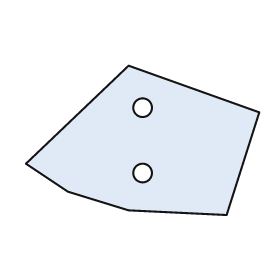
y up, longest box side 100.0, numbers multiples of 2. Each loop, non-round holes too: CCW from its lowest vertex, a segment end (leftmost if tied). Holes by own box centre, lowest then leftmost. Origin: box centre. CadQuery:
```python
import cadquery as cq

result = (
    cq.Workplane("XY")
    .moveTo(36.0, -32.0)
    .lineTo(50.0, 12.0)
    .lineTo(-6.0, 32.0)
    .lineTo(-50.0, -10.0)
    .lineTo(-32.0, -22.0)
    .lineTo(-6.0, -30.0)
    .close()
    .moveTo(0.0, -14.0)
    .circle(4.0)
    .moveTo(0.0, 14.0)
    .circle(4.0)
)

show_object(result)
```